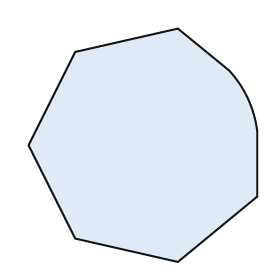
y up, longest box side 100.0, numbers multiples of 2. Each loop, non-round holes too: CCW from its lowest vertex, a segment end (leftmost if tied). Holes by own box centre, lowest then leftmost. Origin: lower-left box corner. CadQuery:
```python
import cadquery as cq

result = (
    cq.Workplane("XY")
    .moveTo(64.0, 0.0)
    .lineTo(98.0, 28.0)
    .lineTo(98.0, 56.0)
    .threePointArc((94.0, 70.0), (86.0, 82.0))
    .lineTo(64.0, 100.0)
    .lineTo(20.0, 90.0)
    .lineTo(0.0, 50.0)
    .lineTo(20.0, 10.0)
    .close()
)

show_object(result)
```